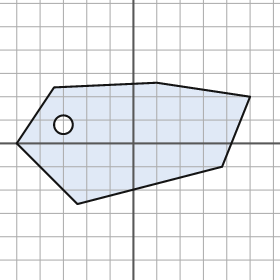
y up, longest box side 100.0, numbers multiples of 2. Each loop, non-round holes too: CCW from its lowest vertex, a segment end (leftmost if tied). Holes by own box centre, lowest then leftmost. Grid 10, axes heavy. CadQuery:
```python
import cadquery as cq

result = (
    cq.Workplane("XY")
    .moveTo(-24.0, -26.0)
    .lineTo(38.0, -10.0)
    .lineTo(50.0, 20.0)
    .lineTo(10.0, 26.0)
    .lineTo(-34.0, 24.0)
    .lineTo(-50.0, 0.0)
    .close()
    .moveTo(-30.0, 8.0)
    .circle(4.0)
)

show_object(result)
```